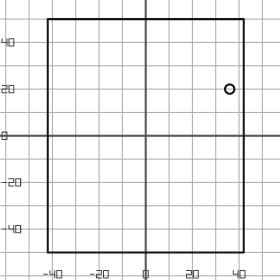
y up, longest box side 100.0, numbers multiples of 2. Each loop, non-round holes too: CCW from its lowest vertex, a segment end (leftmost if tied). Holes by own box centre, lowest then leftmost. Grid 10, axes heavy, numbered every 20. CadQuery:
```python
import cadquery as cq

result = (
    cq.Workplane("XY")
    .moveTo(-42.0, -50.0)
    .lineTo(42.0, -50.0)
    .lineTo(42.0, 50.0)
    .lineTo(-42.0, 50.0)
    .close()
    .moveTo(36.0, 20.0)
    .circle(2.0)
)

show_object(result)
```